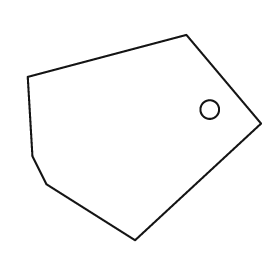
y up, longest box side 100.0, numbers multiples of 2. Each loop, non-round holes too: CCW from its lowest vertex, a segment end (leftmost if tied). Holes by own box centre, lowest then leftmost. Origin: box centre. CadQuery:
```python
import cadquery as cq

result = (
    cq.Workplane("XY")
    .moveTo(-4.0, -44.0)
    .lineTo(50.0, 6.0)
    .lineTo(18.0, 44.0)
    .lineTo(-50.0, 26.0)
    .lineTo(-48.0, -8.0)
    .lineTo(-42.0, -20.0)
    .close()
    .moveTo(28.0, 12.0)
    .circle(4.0)
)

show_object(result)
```